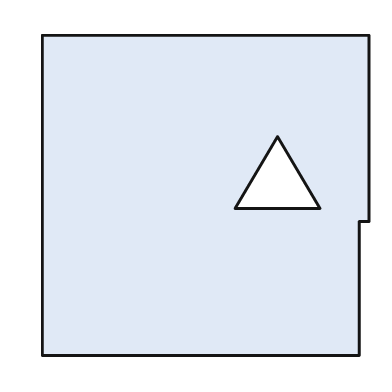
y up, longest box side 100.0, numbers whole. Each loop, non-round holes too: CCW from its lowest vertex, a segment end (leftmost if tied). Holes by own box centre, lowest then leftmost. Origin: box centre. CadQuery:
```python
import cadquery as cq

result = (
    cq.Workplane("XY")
    .moveTo(-50.0, -49.0)
    .lineTo(47.0, -49.0)
    .lineTo(47.0, -8.0)
    .lineTo(50.0, -8.0)
    .lineTo(50.0, 49.0)
    .lineTo(-50.0, 49.0)
    .close()
    .moveTo(9.0, -4.0)
    .lineTo(35.0, -4.0)
    .lineTo(22.0, 18.0)
    .close()
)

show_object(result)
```